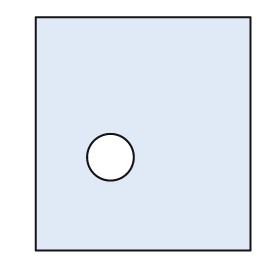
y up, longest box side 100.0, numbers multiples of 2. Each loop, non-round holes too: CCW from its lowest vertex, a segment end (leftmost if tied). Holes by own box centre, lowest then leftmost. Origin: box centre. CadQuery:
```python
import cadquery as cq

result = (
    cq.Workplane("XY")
    .moveTo(-46.0, -50.0)
    .lineTo(46.0, -50.0)
    .lineTo(46.0, 50.0)
    .lineTo(-46.0, 50.0)
    .close()
    .moveTo(-14.0, -10.0)
    .circle(10.0)
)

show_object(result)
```